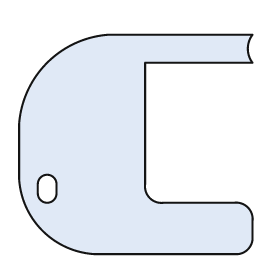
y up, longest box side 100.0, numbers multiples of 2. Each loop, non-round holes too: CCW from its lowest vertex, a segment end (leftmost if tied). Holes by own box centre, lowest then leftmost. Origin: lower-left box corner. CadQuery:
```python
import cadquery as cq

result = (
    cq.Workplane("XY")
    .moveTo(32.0, 0.0)
    .lineTo(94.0, 0.0)
    .threePointArc((98.0, 2.0), (100.0, 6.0))
    .lineTo(100.0, 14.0)
    .threePointArc((98.0, 20.0), (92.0, 22.0))
    .lineTo(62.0, 22.0)
    .threePointArc((56.0, 24.0), (54.0, 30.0))
    .lineTo(54.0, 82.0)
    .lineTo(100.0, 82.0)
    .threePointArc((98.0, 88.0), (100.0, 94.0))
    .lineTo(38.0, 94.0)
    .threePointArc((12.0, 82.0), (0.0, 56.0))
    .lineTo(0.0, 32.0)
    .threePointArc((10.0, 10.0), (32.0, 0.0))
    .close()
    .moveTo(8.0, 26.0)
    .threePointArc((12.0, 22.0), (16.0, 26.0))
    .lineTo(16.0, 30.0)
    .threePointArc((12.0, 34.0), (8.0, 30.0))
    .close()
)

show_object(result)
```